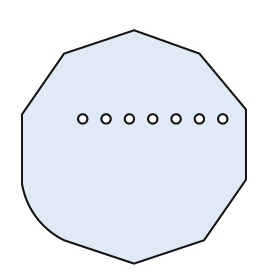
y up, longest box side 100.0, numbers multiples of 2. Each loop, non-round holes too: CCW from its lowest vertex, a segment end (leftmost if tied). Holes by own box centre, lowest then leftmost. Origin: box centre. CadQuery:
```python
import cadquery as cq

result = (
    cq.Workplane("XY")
    .moveTo(0.0, -50.0)
    .lineTo(30.0, -40.0)
    .lineTo(48.0, -14.0)
    .lineTo(48.0, 16.0)
    .lineTo(28.0, 40.0)
    .lineTo(0.0, 50.0)
    .lineTo(-30.0, 40.0)
    .lineTo(-48.0, 14.0)
    .lineTo(-48.0, -16.0)
    .threePointArc((-42.0, -30.0), (-30.0, -40.0))
    .close()
    .moveTo(-22.0, 12.0)
    .circle(2.0)
    .moveTo(-12.0, 12.0)
    .circle(2.0)
    .moveTo(-2.0, 12.0)
    .circle(2.0)
    .moveTo(8.0, 12.0)
    .circle(2.0)
    .moveTo(18.0, 12.0)
    .circle(2.0)
    .moveTo(28.0, 12.0)
    .circle(2.0)
    .moveTo(38.0, 12.0)
    .circle(2.0)
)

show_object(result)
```